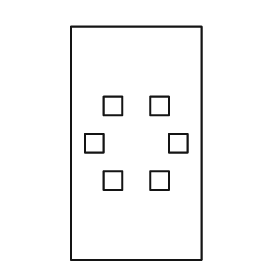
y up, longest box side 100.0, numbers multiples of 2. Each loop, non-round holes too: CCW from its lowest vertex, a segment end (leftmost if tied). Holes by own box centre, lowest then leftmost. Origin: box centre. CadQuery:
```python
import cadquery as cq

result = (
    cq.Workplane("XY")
    .moveTo(-28.0, -50.0)
    .lineTo(28.0, -50.0)
    .lineTo(28.0, 50.0)
    .lineTo(-28.0, 50.0)
    .close()
    .moveTo(-14.0, -20.0)
    .lineTo(-6.0, -20.0)
    .lineTo(-6.0, -12.0)
    .lineTo(-14.0, -12.0)
    .close()
    .moveTo(6.0, -20.0)
    .lineTo(14.0, -20.0)
    .lineTo(14.0, -12.0)
    .lineTo(6.0, -12.0)
    .close()
    .moveTo(-22.0, -4.0)
    .lineTo(-14.0, -4.0)
    .lineTo(-14.0, 4.0)
    .lineTo(-22.0, 4.0)
    .close()
    .moveTo(14.0, -4.0)
    .lineTo(22.0, -4.0)
    .lineTo(22.0, 4.0)
    .lineTo(14.0, 4.0)
    .close()
    .moveTo(-14.0, 12.0)
    .lineTo(-6.0, 12.0)
    .lineTo(-6.0, 20.0)
    .lineTo(-14.0, 20.0)
    .close()
    .moveTo(6.0, 12.0)
    .lineTo(14.0, 12.0)
    .lineTo(14.0, 20.0)
    .lineTo(6.0, 20.0)
    .close()
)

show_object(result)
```